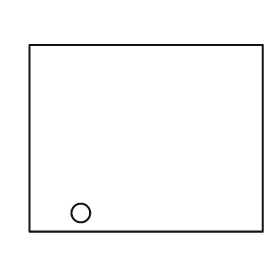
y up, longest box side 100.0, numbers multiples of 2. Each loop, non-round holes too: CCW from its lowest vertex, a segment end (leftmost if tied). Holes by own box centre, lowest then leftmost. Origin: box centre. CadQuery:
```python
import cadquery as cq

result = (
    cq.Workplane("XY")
    .moveTo(-50.0, -40.0)
    .lineTo(50.0, -40.0)
    .lineTo(50.0, 40.0)
    .lineTo(-50.0, 40.0)
    .close()
    .moveTo(-28.0, -32.0)
    .circle(4.0)
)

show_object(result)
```